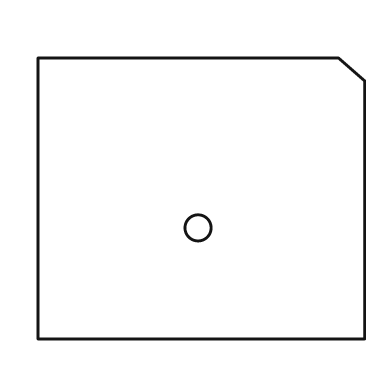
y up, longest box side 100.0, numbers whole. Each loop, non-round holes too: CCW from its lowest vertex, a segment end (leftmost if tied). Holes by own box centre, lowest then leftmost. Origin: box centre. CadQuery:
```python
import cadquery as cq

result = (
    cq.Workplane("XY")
    .moveTo(-50.0, -43.0)
    .lineTo(50.0, -43.0)
    .lineTo(50.0, 36.0)
    .lineTo(42.0, 43.0)
    .lineTo(-50.0, 43.0)
    .close()
    .moveTo(-1.0, -9.0)
    .circle(4.0)
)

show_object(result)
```